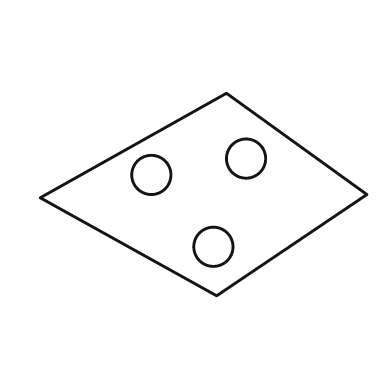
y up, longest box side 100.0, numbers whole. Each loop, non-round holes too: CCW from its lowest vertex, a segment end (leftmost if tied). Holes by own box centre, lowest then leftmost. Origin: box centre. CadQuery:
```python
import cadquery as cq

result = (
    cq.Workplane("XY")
    .moveTo(4.0, -31.0)
    .lineTo(50.0, 0.0)
    .lineTo(7.0, 31.0)
    .lineTo(-50.0, -1.0)
    .close()
    .moveTo(3.0, -16.0)
    .circle(6.0)
    .moveTo(-16.0, 6.0)
    .circle(6.0)
    .moveTo(13.0, 11.0)
    .circle(6.0)
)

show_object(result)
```